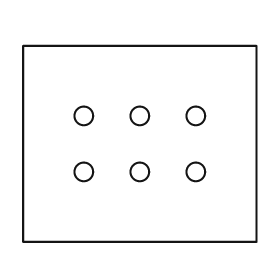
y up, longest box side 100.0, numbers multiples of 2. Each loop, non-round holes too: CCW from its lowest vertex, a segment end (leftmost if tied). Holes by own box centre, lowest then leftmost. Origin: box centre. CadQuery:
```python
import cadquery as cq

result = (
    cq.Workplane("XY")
    .moveTo(-50.0, -42.0)
    .lineTo(50.0, -42.0)
    .lineTo(50.0, 42.0)
    .lineTo(-50.0, 42.0)
    .close()
    .moveTo(-24.0, -12.0)
    .circle(4.0)
    .moveTo(0.0, -12.0)
    .circle(4.0)
    .moveTo(24.0, -12.0)
    .circle(4.0)
    .moveTo(-24.0, 12.0)
    .circle(4.0)
    .moveTo(0.0, 12.0)
    .circle(4.0)
    .moveTo(24.0, 12.0)
    .circle(4.0)
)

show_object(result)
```